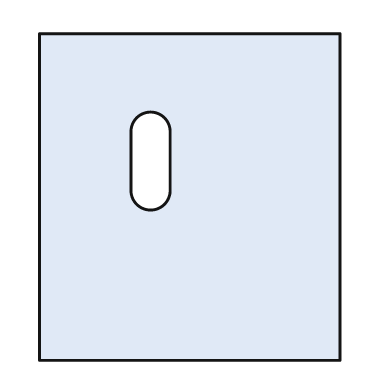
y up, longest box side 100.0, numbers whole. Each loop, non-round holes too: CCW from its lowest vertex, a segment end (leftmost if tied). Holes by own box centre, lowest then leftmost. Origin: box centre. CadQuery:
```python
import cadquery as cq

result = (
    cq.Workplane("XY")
    .moveTo(-46.0, -50.0)
    .lineTo(46.0, -50.0)
    .lineTo(46.0, 50.0)
    .lineTo(-46.0, 50.0)
    .close()
    .moveTo(-18.0, 2.0)
    .threePointArc((-12.0, -4.0), (-6.0, 2.0))
    .lineTo(-6.0, 20.0)
    .threePointArc((-12.0, 26.0), (-18.0, 20.0))
    .close()
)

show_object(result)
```